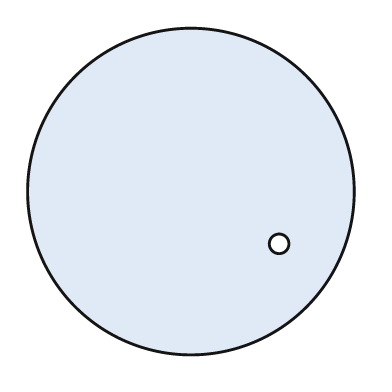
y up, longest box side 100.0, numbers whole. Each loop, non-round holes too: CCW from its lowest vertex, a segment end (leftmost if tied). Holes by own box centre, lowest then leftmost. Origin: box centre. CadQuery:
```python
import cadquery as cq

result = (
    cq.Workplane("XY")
    .moveTo(0.0, 0.0)
    .circle(50.0)
    .moveTo(27.0, -16.0)
    .circle(3.0)
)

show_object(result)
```